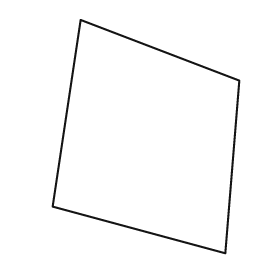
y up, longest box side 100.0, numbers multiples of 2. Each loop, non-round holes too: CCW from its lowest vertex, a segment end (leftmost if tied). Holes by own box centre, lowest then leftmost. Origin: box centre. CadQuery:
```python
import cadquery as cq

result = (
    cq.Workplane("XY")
    .moveTo(34.0, -50.0)
    .lineTo(40.0, 24.0)
    .lineTo(-28.0, 50.0)
    .lineTo(-40.0, -30.0)
    .close()
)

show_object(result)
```